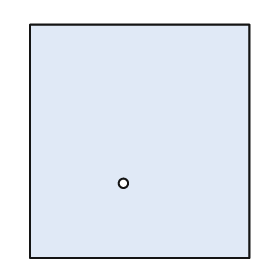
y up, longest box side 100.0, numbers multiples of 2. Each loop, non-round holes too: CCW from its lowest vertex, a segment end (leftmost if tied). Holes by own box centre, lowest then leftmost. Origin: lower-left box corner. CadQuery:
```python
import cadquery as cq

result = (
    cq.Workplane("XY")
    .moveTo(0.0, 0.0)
    .lineTo(94.0, 0.0)
    .lineTo(94.0, 100.0)
    .lineTo(0.0, 100.0)
    .close()
    .moveTo(40.0, 32.0)
    .circle(2.0)
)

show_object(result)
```